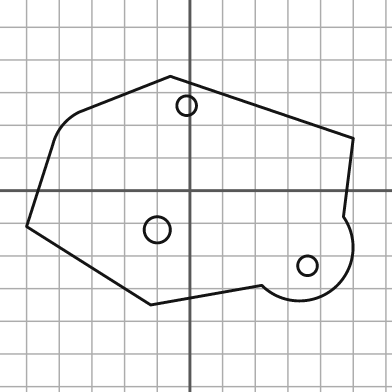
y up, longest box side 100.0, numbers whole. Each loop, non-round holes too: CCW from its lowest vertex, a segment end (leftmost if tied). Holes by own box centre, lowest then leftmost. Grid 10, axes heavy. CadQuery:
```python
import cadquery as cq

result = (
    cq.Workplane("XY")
    .moveTo(-12.0, -35.0)
    .lineTo(22.0, -29.0)
    .threePointArc((44.0, -30.0), (47.0, -8.0))
    .lineTo(50.0, 16.0)
    .lineTo(-6.0, 35.0)
    .lineTo(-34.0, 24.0)
    .threePointArc((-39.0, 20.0), (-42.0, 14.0))
    .lineTo(-50.0, -11.0)
    .close()
    .moveTo(36.0, -23.0)
    .circle(3.0)
    .moveTo(-10.0, -12.0)
    .circle(4.0)
    .moveTo(-1.0, 26.0)
    .circle(3.0)
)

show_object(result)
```